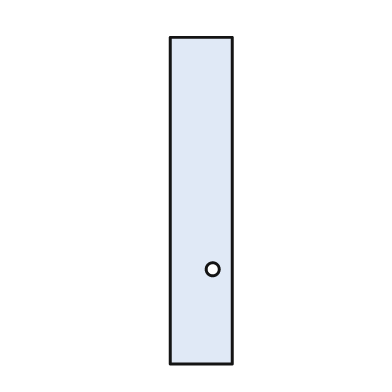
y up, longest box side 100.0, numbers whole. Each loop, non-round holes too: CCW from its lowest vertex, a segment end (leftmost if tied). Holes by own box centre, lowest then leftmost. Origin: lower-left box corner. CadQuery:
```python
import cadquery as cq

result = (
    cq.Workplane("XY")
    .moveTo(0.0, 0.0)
    .lineTo(19.0, 0.0)
    .lineTo(19.0, 100.0)
    .lineTo(0.0, 100.0)
    .close()
    .moveTo(13.0, 29.0)
    .circle(2.0)
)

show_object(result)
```